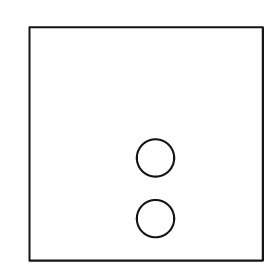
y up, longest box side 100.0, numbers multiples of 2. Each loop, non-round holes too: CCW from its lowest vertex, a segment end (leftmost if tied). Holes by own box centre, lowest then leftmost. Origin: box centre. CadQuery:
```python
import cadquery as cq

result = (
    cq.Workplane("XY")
    .moveTo(-50.0, -50.0)
    .lineTo(50.0, -50.0)
    .lineTo(50.0, 50.0)
    .lineTo(-50.0, 50.0)
    .close()
    .moveTo(4.0, -32.0)
    .circle(8.0)
    .moveTo(4.0, -6.0)
    .circle(8.0)
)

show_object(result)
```